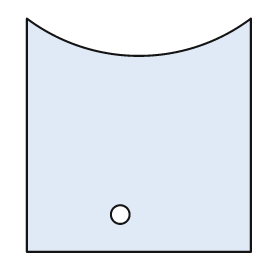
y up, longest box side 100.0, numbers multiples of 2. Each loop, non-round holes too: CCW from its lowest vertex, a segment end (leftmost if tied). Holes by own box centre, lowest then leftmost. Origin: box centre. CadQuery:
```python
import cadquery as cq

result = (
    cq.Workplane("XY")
    .moveTo(-48.0, -50.0)
    .lineTo(48.0, -50.0)
    .lineTo(48.0, 50.0)
    .threePointArc((0.0, 34.0), (-48.0, 50.0))
    .close()
    .moveTo(-8.0, -34.0)
    .circle(4.0)
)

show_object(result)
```